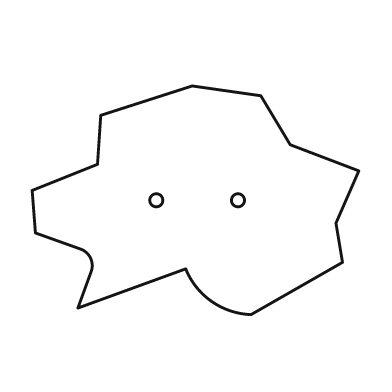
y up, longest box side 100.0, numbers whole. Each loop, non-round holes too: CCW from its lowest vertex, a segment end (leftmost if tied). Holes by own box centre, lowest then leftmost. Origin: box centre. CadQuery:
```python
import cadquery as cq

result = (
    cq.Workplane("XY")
    .moveTo(17.0, -35.0)
    .lineTo(45.0, -19.0)
    .lineTo(43.0, -7.0)
    .lineTo(50.0, 9.0)
    .lineTo(29.0, 17.0)
    .lineTo(20.0, 32.0)
    .lineTo(-1.0, 35.0)
    .lineTo(-29.0, 26.0)
    .lineTo(-30.0, 11.0)
    .lineTo(-50.0, 3.0)
    .lineTo(-49.0, -10.0)
    .lineTo(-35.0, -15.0)
    .threePointArc((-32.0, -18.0), (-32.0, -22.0))
    .lineTo(-36.0, -33.0)
    .lineTo(-3.0, -21.0)
    .threePointArc((5.0, -31.0), (17.0, -35.0))
    .close()
    .moveTo(-12.0, 0.0)
    .circle(2.0)
    .moveTo(13.0, 0.0)
    .circle(2.0)
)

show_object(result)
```